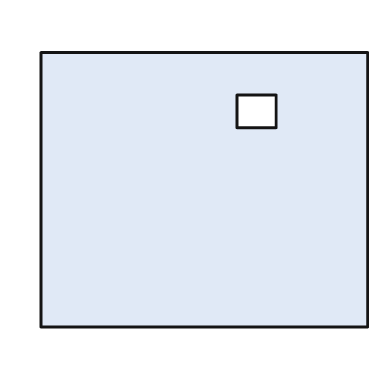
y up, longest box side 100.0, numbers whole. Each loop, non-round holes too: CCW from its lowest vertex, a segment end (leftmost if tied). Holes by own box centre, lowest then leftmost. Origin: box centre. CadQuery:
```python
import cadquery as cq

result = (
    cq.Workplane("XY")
    .moveTo(-50.0, -42.0)
    .lineTo(50.0, -42.0)
    .lineTo(50.0, 42.0)
    .lineTo(-50.0, 42.0)
    .close()
    .moveTo(10.0, 19.0)
    .lineTo(22.0, 19.0)
    .lineTo(22.0, 29.0)
    .lineTo(10.0, 29.0)
    .close()
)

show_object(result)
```